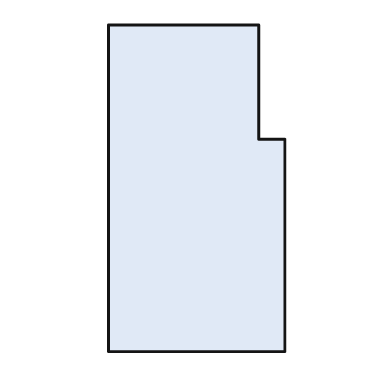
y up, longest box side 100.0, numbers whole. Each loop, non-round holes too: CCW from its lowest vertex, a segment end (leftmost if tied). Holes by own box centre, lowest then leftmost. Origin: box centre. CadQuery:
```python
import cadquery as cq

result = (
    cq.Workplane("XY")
    .moveTo(-27.0, -50.0)
    .lineTo(27.0, -50.0)
    .lineTo(27.0, 15.0)
    .lineTo(19.0, 15.0)
    .lineTo(19.0, 50.0)
    .lineTo(-27.0, 50.0)
    .close()
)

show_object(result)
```